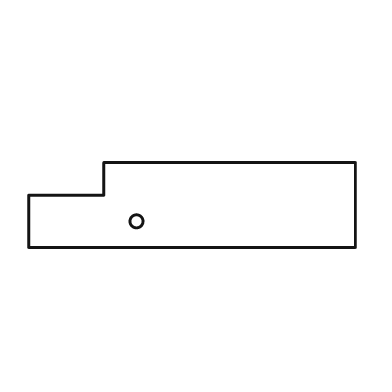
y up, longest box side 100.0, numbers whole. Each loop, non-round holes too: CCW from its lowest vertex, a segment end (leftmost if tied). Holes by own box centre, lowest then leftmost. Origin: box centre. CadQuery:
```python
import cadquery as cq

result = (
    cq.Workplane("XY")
    .moveTo(-50.0, -13.0)
    .lineTo(50.0, -13.0)
    .lineTo(50.0, 13.0)
    .lineTo(-27.0, 13.0)
    .lineTo(-27.0, 3.0)
    .lineTo(-50.0, 3.0)
    .close()
    .moveTo(-17.0, -5.0)
    .circle(2.0)
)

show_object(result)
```